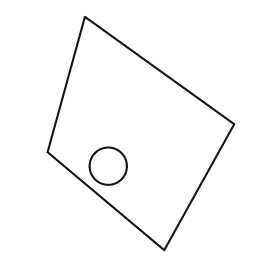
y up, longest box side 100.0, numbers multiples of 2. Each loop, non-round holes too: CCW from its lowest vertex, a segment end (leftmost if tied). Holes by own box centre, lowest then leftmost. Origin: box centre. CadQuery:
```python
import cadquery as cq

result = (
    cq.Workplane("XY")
    .moveTo(10.0, -50.0)
    .lineTo(40.0, 4.0)
    .lineTo(-24.0, 50.0)
    .lineTo(-40.0, -8.0)
    .close()
    .moveTo(-14.0, -14.0)
    .circle(8.0)
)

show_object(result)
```